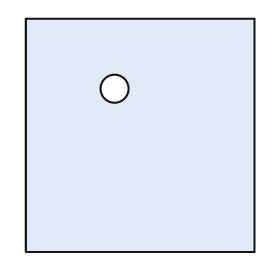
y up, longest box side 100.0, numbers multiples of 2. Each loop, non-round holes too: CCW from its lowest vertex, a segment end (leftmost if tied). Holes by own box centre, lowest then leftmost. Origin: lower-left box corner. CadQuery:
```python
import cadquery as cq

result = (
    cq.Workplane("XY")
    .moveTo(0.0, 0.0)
    .lineTo(98.0, 0.0)
    .lineTo(98.0, 100.0)
    .lineTo(0.0, 100.0)
    .close()
    .moveTo(38.0, 70.0)
    .circle(6.0)
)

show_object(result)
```